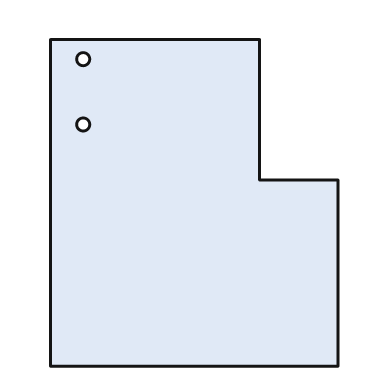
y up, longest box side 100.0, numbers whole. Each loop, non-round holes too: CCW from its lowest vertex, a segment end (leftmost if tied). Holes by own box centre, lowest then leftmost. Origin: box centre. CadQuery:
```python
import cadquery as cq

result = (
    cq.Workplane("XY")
    .moveTo(-44.0, -50.0)
    .lineTo(44.0, -50.0)
    .lineTo(44.0, 7.0)
    .lineTo(20.0, 7.0)
    .lineTo(20.0, 50.0)
    .lineTo(-44.0, 50.0)
    .close()
    .moveTo(-34.0, 24.0)
    .circle(2.0)
    .moveTo(-34.0, 44.0)
    .circle(2.0)
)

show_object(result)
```